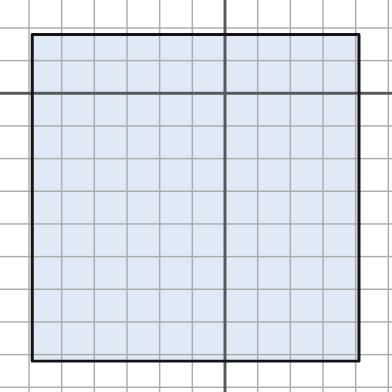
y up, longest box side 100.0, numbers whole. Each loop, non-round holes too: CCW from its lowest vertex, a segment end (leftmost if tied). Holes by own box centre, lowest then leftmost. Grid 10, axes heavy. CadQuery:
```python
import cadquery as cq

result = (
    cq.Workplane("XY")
    .moveTo(-59.0, -82.0)
    .lineTo(41.0, -82.0)
    .lineTo(41.0, 18.0)
    .lineTo(-59.0, 18.0)
    .close()
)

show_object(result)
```